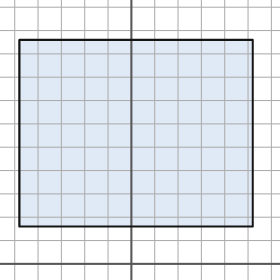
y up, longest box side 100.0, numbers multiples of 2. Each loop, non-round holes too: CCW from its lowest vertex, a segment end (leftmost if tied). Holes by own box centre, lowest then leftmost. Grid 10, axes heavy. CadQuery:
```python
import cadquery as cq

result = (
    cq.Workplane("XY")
    .moveTo(-48.0, 16.0)
    .lineTo(52.0, 16.0)
    .lineTo(52.0, 96.0)
    .lineTo(-48.0, 96.0)
    .close()
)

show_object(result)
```